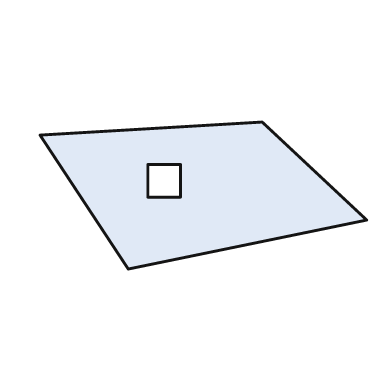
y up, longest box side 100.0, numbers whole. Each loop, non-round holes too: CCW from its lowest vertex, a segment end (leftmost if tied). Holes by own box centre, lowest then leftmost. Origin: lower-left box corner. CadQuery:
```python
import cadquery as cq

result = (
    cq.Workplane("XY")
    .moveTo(27.0, 0.0)
    .lineTo(100.0, 15.0)
    .lineTo(68.0, 45.0)
    .lineTo(0.0, 41.0)
    .close()
    .moveTo(33.0, 22.0)
    .lineTo(43.0, 22.0)
    .lineTo(43.0, 32.0)
    .lineTo(33.0, 32.0)
    .close()
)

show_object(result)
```